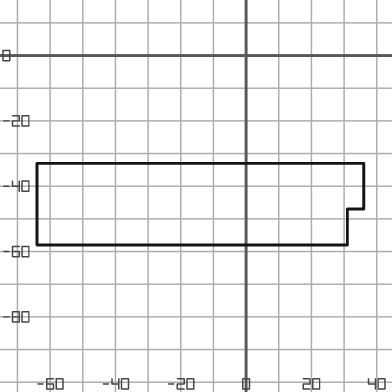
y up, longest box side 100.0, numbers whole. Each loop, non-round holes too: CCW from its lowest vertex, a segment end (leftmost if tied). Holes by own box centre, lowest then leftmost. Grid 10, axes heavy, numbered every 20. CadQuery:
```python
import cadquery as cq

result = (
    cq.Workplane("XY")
    .moveTo(-64.0, -58.0)
    .lineTo(31.0, -58.0)
    .lineTo(31.0, -47.0)
    .lineTo(36.0, -47.0)
    .lineTo(36.0, -33.0)
    .lineTo(-64.0, -33.0)
    .close()
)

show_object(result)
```